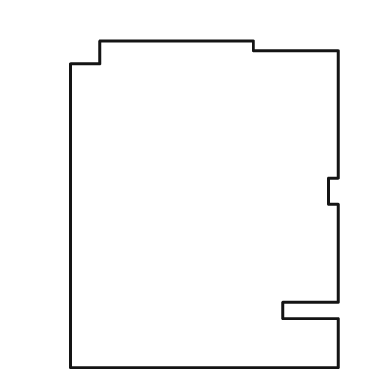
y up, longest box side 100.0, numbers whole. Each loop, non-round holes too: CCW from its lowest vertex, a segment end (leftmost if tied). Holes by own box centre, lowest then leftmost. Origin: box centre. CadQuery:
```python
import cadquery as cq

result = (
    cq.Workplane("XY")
    .moveTo(-41.0, -50.0)
    .lineTo(41.0, -50.0)
    .lineTo(41.0, -35.0)
    .lineTo(24.0, -35.0)
    .lineTo(24.0, -30.0)
    .lineTo(41.0, -30.0)
    .lineTo(41.0, 0.0)
    .lineTo(38.0, 0.0)
    .lineTo(38.0, 8.0)
    .lineTo(41.0, 8.0)
    .lineTo(41.0, 47.0)
    .lineTo(15.0, 47.0)
    .lineTo(15.0, 50.0)
    .lineTo(-32.0, 50.0)
    .lineTo(-32.0, 43.0)
    .lineTo(-41.0, 43.0)
    .close()
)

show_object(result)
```